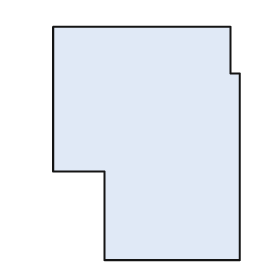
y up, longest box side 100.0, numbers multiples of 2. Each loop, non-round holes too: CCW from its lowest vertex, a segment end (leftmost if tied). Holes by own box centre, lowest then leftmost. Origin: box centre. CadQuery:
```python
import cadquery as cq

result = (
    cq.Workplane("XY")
    .moveTo(-18.0, -50.0)
    .lineTo(40.0, -50.0)
    .lineTo(40.0, 30.0)
    .lineTo(36.0, 30.0)
    .lineTo(36.0, 50.0)
    .lineTo(-40.0, 50.0)
    .lineTo(-40.0, -12.0)
    .lineTo(-18.0, -12.0)
    .close()
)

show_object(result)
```